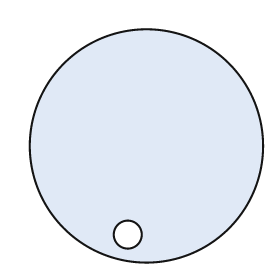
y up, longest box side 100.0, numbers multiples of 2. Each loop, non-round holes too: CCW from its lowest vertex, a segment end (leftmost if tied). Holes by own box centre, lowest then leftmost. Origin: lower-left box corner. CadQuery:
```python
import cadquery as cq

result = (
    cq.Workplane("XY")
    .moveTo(50.0, 50.0)
    .circle(50.0)
    .moveTo(42.0, 12.0)
    .circle(6.0)
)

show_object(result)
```